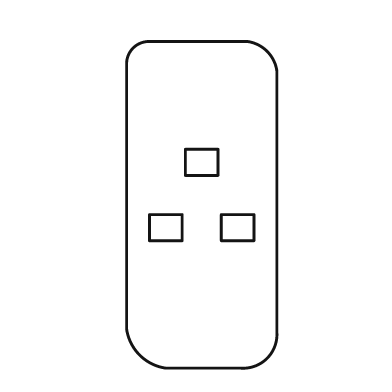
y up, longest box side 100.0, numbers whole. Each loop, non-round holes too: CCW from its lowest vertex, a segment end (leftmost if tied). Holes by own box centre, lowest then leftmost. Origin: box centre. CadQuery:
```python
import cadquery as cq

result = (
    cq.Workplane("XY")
    .moveTo(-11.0, -50.0)
    .lineTo(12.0, -50.0)
    .threePointArc((20.0, -47.0), (23.0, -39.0))
    .lineTo(23.0, 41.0)
    .threePointArc((20.0, 47.0), (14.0, 50.0))
    .lineTo(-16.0, 50.0)
    .threePointArc((-21.0, 48.0), (-23.0, 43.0))
    .lineTo(-23.0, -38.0)
    .threePointArc((-19.0, -46.0), (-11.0, -50.0))
    .close()
    .moveTo(-16.0, -11.0)
    .lineTo(-6.0, -11.0)
    .lineTo(-6.0, -3.0)
    .lineTo(-16.0, -3.0)
    .close()
    .moveTo(6.0, -11.0)
    .lineTo(16.0, -11.0)
    .lineTo(16.0, -3.0)
    .lineTo(6.0, -3.0)
    .close()
    .moveTo(-5.0, 9.0)
    .lineTo(5.0, 9.0)
    .lineTo(5.0, 17.0)
    .lineTo(-5.0, 17.0)
    .close()
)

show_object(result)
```